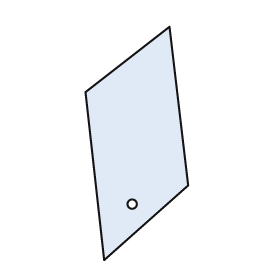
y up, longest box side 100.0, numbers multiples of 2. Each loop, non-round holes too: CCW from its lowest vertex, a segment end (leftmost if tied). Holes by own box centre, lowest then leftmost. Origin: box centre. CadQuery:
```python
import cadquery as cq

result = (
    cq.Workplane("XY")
    .moveTo(-14.0, -50.0)
    .lineTo(22.0, -18.0)
    .lineTo(14.0, 50.0)
    .lineTo(-22.0, 22.0)
    .close()
    .moveTo(-2.0, -26.0)
    .circle(2.0)
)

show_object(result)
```